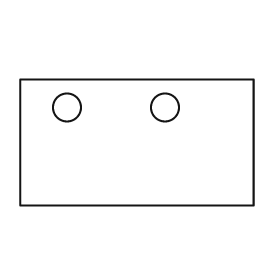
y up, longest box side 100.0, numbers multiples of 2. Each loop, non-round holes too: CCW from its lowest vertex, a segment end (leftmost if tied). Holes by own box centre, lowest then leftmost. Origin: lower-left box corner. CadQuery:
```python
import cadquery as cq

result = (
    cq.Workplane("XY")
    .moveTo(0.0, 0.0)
    .lineTo(100.0, 0.0)
    .lineTo(100.0, 54.0)
    .lineTo(0.0, 54.0)
    .close()
    .moveTo(20.0, 42.0)
    .circle(6.0)
    .moveTo(62.0, 42.0)
    .circle(6.0)
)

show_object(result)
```